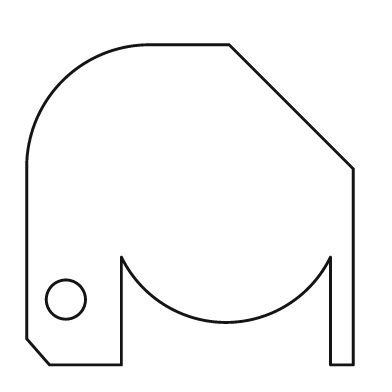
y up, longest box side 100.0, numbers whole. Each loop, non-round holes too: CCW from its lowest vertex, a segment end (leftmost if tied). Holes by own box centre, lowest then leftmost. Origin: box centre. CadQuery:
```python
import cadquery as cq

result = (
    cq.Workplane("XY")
    .moveTo(-43.0, -49.0)
    .lineTo(-21.0, -49.0)
    .lineTo(-21.0, -16.0)
    .threePointArc((11.0, -36.0), (43.0, -16.0))
    .lineTo(43.0, -49.0)
    .lineTo(50.0, -49.0)
    .lineTo(50.0, 11.0)
    .lineTo(12.0, 49.0)
    .lineTo(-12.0, 49.0)
    .threePointArc((-39.0, 38.0), (-50.0, 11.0))
    .lineTo(-50.0, -41.0)
    .close()
    .moveTo(-38.0, -29.0)
    .circle(6.0)
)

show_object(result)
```